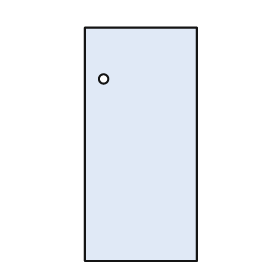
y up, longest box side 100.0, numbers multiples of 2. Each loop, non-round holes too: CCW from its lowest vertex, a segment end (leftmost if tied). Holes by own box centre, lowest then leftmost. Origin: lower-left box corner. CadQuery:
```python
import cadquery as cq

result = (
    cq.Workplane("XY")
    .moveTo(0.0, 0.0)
    .lineTo(48.0, 0.0)
    .lineTo(48.0, 100.0)
    .lineTo(0.0, 100.0)
    .close()
    .moveTo(8.0, 78.0)
    .circle(2.0)
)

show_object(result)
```